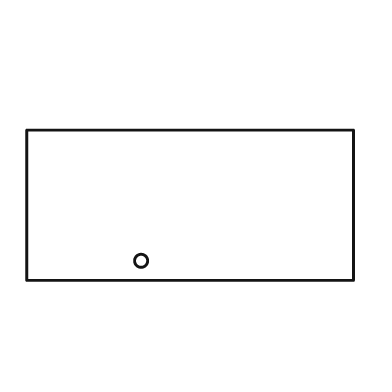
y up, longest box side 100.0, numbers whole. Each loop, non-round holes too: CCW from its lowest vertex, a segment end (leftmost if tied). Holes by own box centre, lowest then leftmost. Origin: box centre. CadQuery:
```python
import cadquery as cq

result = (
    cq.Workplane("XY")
    .moveTo(-50.0, -23.0)
    .lineTo(50.0, -23.0)
    .lineTo(50.0, 23.0)
    .lineTo(-50.0, 23.0)
    .close()
    .moveTo(-15.0, -17.0)
    .circle(2.0)
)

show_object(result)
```